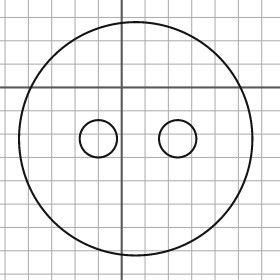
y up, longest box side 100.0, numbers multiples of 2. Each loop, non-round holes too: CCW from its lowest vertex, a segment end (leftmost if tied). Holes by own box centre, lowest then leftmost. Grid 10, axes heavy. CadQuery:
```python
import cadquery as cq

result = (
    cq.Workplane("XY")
    .moveTo(6.0, -22.0)
    .circle(50.0)
    .moveTo(-10.0, -22.0)
    .circle(8.0)
    .moveTo(24.0, -22.0)
    .circle(8.0)
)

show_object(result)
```